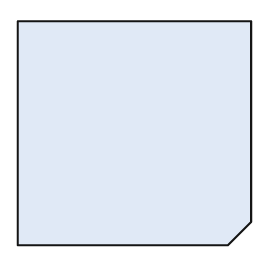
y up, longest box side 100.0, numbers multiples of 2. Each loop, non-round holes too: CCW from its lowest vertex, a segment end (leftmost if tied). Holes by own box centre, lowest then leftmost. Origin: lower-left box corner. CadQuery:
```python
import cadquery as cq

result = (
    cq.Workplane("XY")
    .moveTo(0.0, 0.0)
    .lineTo(90.0, 0.0)
    .lineTo(100.0, 10.0)
    .lineTo(100.0, 96.0)
    .lineTo(0.0, 96.0)
    .close()
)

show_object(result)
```